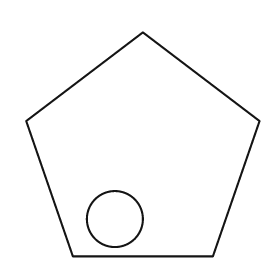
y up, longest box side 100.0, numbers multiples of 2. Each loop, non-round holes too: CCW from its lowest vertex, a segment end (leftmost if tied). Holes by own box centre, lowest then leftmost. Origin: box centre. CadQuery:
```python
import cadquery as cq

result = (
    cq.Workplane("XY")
    .moveTo(-30.0, -48.0)
    .lineTo(30.0, -48.0)
    .lineTo(50.0, 10.0)
    .lineTo(0.0, 48.0)
    .lineTo(-50.0, 10.0)
    .close()
    .moveTo(-12.0, -32.0)
    .circle(12.0)
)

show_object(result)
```